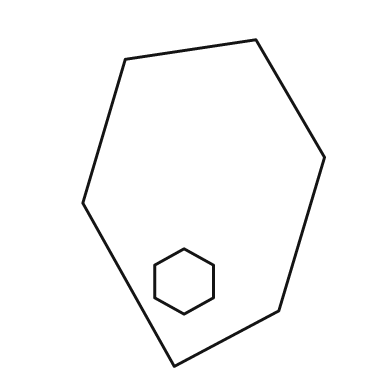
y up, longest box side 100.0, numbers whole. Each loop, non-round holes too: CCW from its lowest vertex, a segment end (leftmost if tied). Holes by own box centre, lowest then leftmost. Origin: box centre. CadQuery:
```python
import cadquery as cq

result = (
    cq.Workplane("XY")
    .moveTo(-9.0, -50.0)
    .lineTo(23.0, -33.0)
    .lineTo(37.0, 14.0)
    .lineTo(16.0, 50.0)
    .lineTo(-24.0, 44.0)
    .lineTo(-37.0, 0.0)
    .close()
    .moveTo(-6.0, -34.0)
    .lineTo(3.0, -29.0)
    .lineTo(3.0, -19.0)
    .lineTo(-6.0, -14.0)
    .lineTo(-15.0, -19.0)
    .lineTo(-15.0, -29.0)
    .close()
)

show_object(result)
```